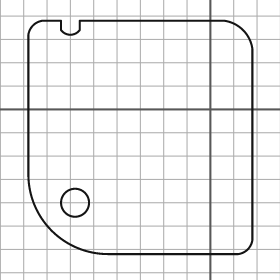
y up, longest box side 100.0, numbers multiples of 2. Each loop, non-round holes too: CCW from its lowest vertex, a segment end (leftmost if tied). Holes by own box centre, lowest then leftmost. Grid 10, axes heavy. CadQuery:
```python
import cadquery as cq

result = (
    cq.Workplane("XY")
    .moveTo(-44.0, -62.0)
    .lineTo(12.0, -62.0)
    .threePointArc((16.0, -60.0), (18.0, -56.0))
    .lineTo(18.0, 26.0)
    .threePointArc((14.0, 34.0), (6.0, 38.0))
    .lineTo(-56.0, 38.0)
    .lineTo(-56.0, 34.0)
    .threePointArc((-60.0, 32.0), (-64.0, 34.0))
    .lineTo(-64.0, 38.0)
    .lineTo(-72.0, 38.0)
    .threePointArc((-76.0, 36.0), (-78.0, 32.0))
    .lineTo(-78.0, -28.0)
    .threePointArc((-68.0, -52.0), (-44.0, -62.0))
    .close()
    .moveTo(-58.0, -40.0)
    .circle(6.0)
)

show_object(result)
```